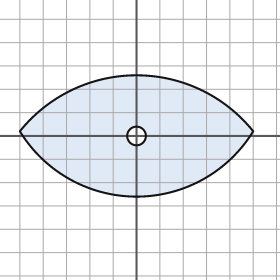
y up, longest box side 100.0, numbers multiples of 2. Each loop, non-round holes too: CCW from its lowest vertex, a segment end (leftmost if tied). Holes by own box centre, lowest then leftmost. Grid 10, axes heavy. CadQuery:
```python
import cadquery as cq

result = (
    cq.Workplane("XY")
    .moveTo(-50.0, 2.0)
    .threePointArc((0.0, -26.0), (50.0, 2.0))
    .threePointArc((0.0, 26.0), (-50.0, 2.0))
    .close()
    .moveTo(0.0, 0.0)
    .circle(4.0)
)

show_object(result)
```